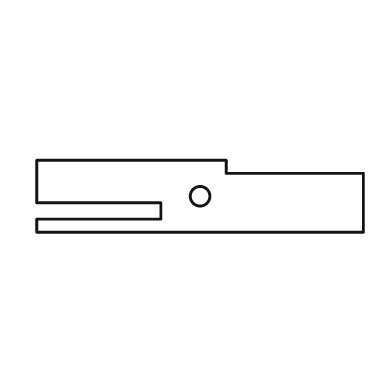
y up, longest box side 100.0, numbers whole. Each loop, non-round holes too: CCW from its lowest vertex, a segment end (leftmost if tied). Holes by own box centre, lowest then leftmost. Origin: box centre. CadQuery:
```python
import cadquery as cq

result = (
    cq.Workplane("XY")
    .moveTo(-50.0, -11.0)
    .lineTo(50.0, -11.0)
    .lineTo(50.0, 7.0)
    .lineTo(8.0, 7.0)
    .lineTo(8.0, 11.0)
    .lineTo(-50.0, 11.0)
    .lineTo(-50.0, -2.0)
    .lineTo(-12.0, -2.0)
    .lineTo(-12.0, -7.0)
    .lineTo(-50.0, -7.0)
    .close()
    .moveTo(0.0, 0.0)
    .circle(3.0)
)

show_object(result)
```